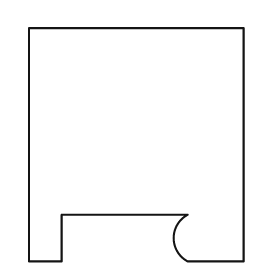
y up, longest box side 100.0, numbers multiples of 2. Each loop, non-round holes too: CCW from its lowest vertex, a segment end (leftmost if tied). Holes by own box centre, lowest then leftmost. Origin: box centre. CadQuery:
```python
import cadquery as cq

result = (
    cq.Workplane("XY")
    .moveTo(-46.0, -50.0)
    .lineTo(-32.0, -50.0)
    .lineTo(-32.0, -30.0)
    .lineTo(22.0, -30.0)
    .threePointArc((16.0, -40.0), (22.0, -50.0))
    .lineTo(46.0, -50.0)
    .lineTo(46.0, 50.0)
    .lineTo(-46.0, 50.0)
    .close()
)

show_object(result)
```